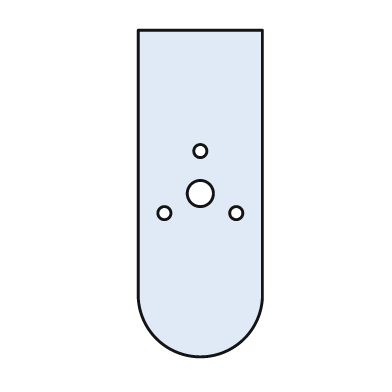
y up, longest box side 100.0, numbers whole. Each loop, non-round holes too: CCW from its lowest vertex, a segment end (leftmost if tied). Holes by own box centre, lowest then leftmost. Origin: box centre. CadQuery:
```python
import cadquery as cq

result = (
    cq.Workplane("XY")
    .moveTo(-19.0, -32.0)
    .threePointArc((0.0, -50.0), (19.0, -32.0))
    .lineTo(19.0, 50.0)
    .lineTo(-19.0, 50.0)
    .close()
    .moveTo(-11.0, -6.0)
    .circle(2.0)
    .moveTo(11.0, -6.0)
    .circle(2.0)
    .moveTo(0.0, 0.0)
    .circle(4.0)
    .moveTo(0.0, 13.0)
    .circle(2.0)
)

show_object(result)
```